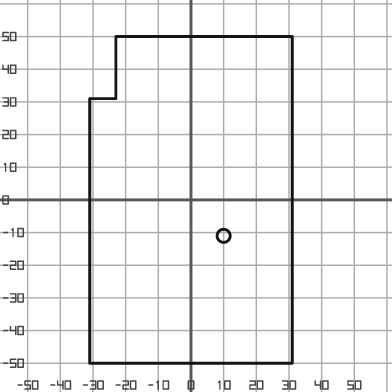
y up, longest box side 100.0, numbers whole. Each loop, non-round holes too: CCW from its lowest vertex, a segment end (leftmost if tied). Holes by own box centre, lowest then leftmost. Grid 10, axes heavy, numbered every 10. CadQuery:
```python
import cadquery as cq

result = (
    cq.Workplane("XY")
    .moveTo(-31.0, -50.0)
    .lineTo(31.0, -50.0)
    .lineTo(31.0, 50.0)
    .lineTo(-23.0, 50.0)
    .lineTo(-23.0, 31.0)
    .lineTo(-31.0, 31.0)
    .close()
    .moveTo(10.0, -11.0)
    .circle(2.0)
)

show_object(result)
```